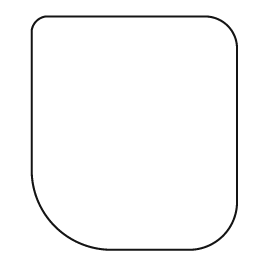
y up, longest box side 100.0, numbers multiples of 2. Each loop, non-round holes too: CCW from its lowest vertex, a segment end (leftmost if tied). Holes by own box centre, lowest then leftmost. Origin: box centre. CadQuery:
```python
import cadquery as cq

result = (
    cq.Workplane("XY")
    .moveTo(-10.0, -50.0)
    .lineTo(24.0, -50.0)
    .threePointArc((38.0, -44.0), (44.0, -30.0))
    .lineTo(44.0, 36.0)
    .threePointArc((40.0, 46.0), (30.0, 50.0))
    .lineTo(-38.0, 50.0)
    .threePointArc((-42.0, 48.0), (-44.0, 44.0))
    .lineTo(-44.0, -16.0)
    .threePointArc((-34.0, -40.0), (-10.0, -50.0))
    .close()
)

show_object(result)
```